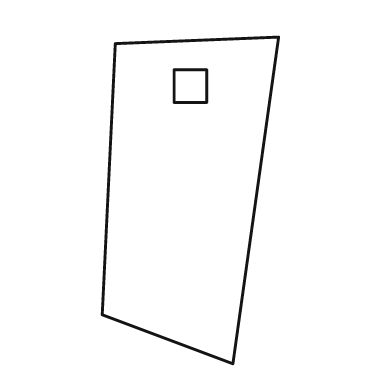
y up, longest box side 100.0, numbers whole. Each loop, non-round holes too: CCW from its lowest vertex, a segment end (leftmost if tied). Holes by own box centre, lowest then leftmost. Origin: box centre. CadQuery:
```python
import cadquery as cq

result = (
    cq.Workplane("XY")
    .moveTo(13.0, -50.0)
    .lineTo(27.0, 50.0)
    .lineTo(-23.0, 48.0)
    .lineTo(-27.0, -35.0)
    .close()
    .moveTo(-5.0, 30.0)
    .lineTo(5.0, 30.0)
    .lineTo(5.0, 40.0)
    .lineTo(-5.0, 40.0)
    .close()
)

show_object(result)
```